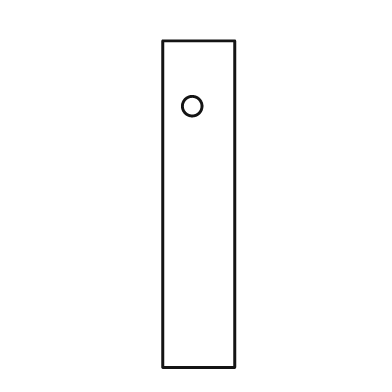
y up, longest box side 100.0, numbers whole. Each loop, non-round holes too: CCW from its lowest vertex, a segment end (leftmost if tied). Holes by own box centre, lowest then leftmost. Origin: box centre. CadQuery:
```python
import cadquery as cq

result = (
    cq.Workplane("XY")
    .moveTo(-11.0, -50.0)
    .lineTo(11.0, -50.0)
    .lineTo(11.0, 50.0)
    .lineTo(-11.0, 50.0)
    .close()
    .moveTo(-2.0, 30.0)
    .circle(3.0)
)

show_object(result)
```